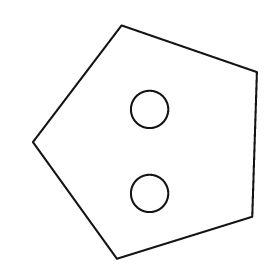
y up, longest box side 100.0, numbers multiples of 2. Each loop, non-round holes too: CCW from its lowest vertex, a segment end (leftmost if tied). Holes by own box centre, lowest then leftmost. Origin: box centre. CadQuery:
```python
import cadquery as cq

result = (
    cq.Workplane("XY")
    .moveTo(-12.0, -50.0)
    .lineTo(46.0, -32.0)
    .lineTo(48.0, 30.0)
    .lineTo(-10.0, 50.0)
    .lineTo(-48.0, 0.0)
    .close()
    .moveTo(2.0, -22.0)
    .circle(8.0)
    .moveTo(2.0, 14.0)
    .circle(8.0)
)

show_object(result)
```